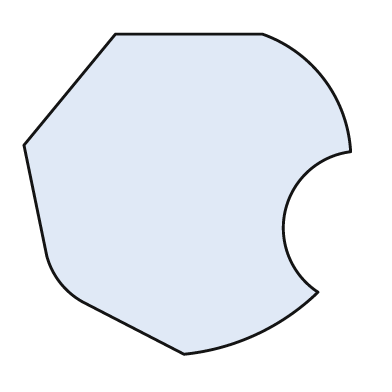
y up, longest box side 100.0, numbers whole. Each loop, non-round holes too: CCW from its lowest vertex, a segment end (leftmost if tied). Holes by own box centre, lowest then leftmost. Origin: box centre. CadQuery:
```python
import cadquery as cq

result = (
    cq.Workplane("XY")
    .moveTo(-1.0, -49.0)
    .threePointArc((21.0, -43.0), (40.0, -30.0))
    .threePointArc((30.0, -5.0), (50.0, 13.0))
    .threePointArc((42.0, 35.0), (23.0, 49.0))
    .lineTo(-22.0, 49.0)
    .lineTo(-50.0, 15.0)
    .lineTo(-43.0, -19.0)
    .threePointArc((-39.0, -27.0), (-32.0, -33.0))
    .close()
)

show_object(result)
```